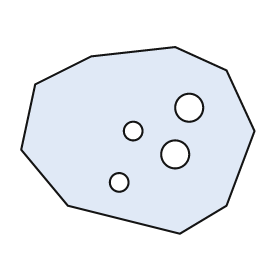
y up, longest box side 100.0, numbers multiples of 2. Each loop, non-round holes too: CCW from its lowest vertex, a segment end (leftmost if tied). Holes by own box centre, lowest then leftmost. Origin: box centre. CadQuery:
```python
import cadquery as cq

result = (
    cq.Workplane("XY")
    .moveTo(18.0, -40.0)
    .lineTo(38.0, -28.0)
    .lineTo(50.0, 4.0)
    .lineTo(38.0, 30.0)
    .lineTo(16.0, 40.0)
    .lineTo(-20.0, 36.0)
    .lineTo(-44.0, 24.0)
    .lineTo(-50.0, -4.0)
    .lineTo(-30.0, -28.0)
    .close()
    .moveTo(-8.0, -18.0)
    .circle(4.0)
    .moveTo(16.0, -6.0)
    .circle(6.0)
    .moveTo(-2.0, 4.0)
    .circle(4.0)
    .moveTo(22.0, 14.0)
    .circle(6.0)
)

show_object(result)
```